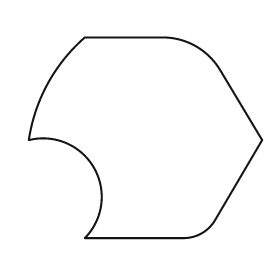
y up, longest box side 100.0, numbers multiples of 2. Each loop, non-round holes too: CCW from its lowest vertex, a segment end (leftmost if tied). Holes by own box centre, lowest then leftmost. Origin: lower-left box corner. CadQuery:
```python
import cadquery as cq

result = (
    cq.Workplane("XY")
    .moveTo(24.0, 0.0)
    .lineTo(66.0, 0.0)
    .threePointArc((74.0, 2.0), (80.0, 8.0))
    .lineTo(100.0, 42.0)
    .lineTo(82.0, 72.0)
    .threePointArc((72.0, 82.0), (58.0, 86.0))
    .lineTo(24.0, 86.0)
    .threePointArc((8.0, 66.0), (0.0, 42.0))
    .threePointArc((28.0, 30.0), (24.0, 0.0))
    .close()
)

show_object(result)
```